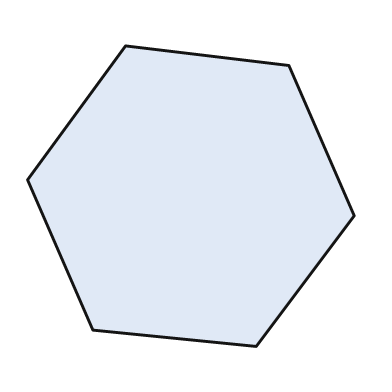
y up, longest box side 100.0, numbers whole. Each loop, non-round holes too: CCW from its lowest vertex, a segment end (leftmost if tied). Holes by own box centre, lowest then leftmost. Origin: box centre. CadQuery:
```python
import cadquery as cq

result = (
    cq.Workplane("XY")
    .moveTo(20.0, -46.0)
    .lineTo(50.0, -6.0)
    .lineTo(30.0, 40.0)
    .lineTo(-20.0, 46.0)
    .lineTo(-50.0, 5.0)
    .lineTo(-30.0, -41.0)
    .close()
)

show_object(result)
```